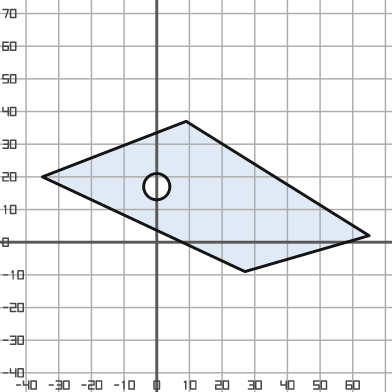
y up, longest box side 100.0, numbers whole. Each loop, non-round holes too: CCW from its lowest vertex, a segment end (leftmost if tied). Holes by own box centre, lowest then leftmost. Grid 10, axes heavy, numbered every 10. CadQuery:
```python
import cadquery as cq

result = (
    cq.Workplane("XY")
    .moveTo(27.0, -9.0)
    .lineTo(65.0, 2.0)
    .lineTo(9.0, 37.0)
    .lineTo(-35.0, 20.0)
    .close()
    .moveTo(0.0, 17.0)
    .circle(4.0)
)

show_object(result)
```